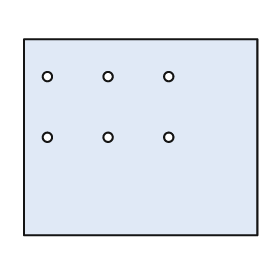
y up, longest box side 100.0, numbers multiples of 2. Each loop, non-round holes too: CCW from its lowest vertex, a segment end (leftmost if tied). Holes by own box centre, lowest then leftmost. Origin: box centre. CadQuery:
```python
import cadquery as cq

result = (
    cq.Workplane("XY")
    .moveTo(-50.0, -42.0)
    .lineTo(50.0, -42.0)
    .lineTo(50.0, 42.0)
    .lineTo(-50.0, 42.0)
    .close()
    .moveTo(-40.0, 0.0)
    .circle(2.0)
    .moveTo(-14.0, 0.0)
    .circle(2.0)
    .moveTo(12.0, 0.0)
    .circle(2.0)
    .moveTo(-40.0, 26.0)
    .circle(2.0)
    .moveTo(-14.0, 26.0)
    .circle(2.0)
    .moveTo(12.0, 26.0)
    .circle(2.0)
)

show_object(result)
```